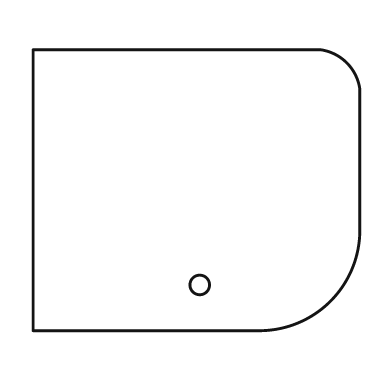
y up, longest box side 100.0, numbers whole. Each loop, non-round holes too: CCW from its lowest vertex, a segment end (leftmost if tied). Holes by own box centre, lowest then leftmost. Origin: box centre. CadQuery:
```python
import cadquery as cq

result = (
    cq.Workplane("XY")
    .moveTo(-50.0, -43.0)
    .lineTo(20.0, -43.0)
    .threePointArc((41.0, -34.0), (50.0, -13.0))
    .lineTo(50.0, 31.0)
    .threePointArc((46.0, 39.0), (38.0, 43.0))
    .lineTo(-50.0, 43.0)
    .close()
    .moveTo(1.0, -29.0)
    .circle(3.0)
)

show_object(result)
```